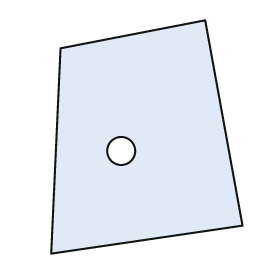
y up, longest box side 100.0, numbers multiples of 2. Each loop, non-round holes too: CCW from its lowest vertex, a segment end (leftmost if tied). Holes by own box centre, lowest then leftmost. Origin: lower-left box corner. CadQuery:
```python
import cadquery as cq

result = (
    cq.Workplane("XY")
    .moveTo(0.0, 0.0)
    .lineTo(82.0, 12.0)
    .lineTo(66.0, 100.0)
    .lineTo(4.0, 88.0)
    .close()
    .moveTo(30.0, 44.0)
    .circle(6.0)
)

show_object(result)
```